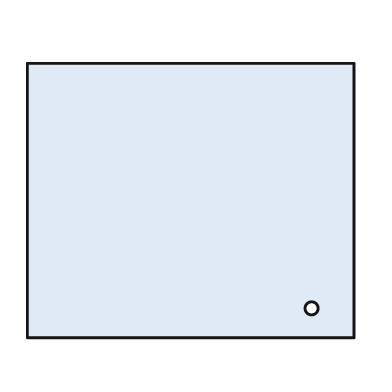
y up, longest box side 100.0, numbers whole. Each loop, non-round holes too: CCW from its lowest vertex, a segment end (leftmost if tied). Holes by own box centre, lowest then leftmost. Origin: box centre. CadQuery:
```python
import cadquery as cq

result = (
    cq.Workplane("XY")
    .moveTo(-50.0, -42.0)
    .lineTo(50.0, -42.0)
    .lineTo(50.0, 42.0)
    .lineTo(-50.0, 42.0)
    .close()
    .moveTo(37.0, -33.0)
    .circle(2.0)
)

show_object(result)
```